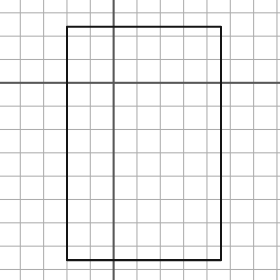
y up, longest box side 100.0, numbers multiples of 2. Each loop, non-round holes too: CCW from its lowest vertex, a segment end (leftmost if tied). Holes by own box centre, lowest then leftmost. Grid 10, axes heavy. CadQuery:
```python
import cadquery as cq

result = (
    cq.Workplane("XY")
    .moveTo(-20.0, -76.0)
    .lineTo(46.0, -76.0)
    .lineTo(46.0, 24.0)
    .lineTo(-20.0, 24.0)
    .close()
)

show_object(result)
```